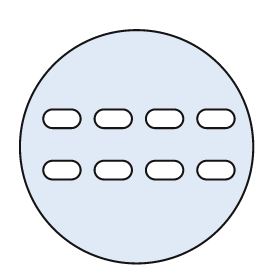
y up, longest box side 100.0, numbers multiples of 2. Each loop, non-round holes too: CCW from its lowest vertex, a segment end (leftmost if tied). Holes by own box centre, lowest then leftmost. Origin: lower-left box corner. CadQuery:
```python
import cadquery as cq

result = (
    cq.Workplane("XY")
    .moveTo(50.0, 50.0)
    .circle(50.0)
    .moveTo(14.0, 36.0)
    .lineTo(22.0, 36.0)
    .threePointArc((26.0, 40.0), (22.0, 44.0))
    .lineTo(14.0, 44.0)
    .threePointArc((10.0, 40.0), (14.0, 36.0))
    .close()
    .moveTo(36.0, 36.0)
    .lineTo(44.0, 36.0)
    .threePointArc((48.0, 40.0), (44.0, 44.0))
    .lineTo(36.0, 44.0)
    .threePointArc((32.0, 40.0), (36.0, 36.0))
    .close()
    .moveTo(58.0, 36.0)
    .lineTo(66.0, 36.0)
    .threePointArc((70.0, 40.0), (66.0, 44.0))
    .lineTo(58.0, 44.0)
    .threePointArc((54.0, 40.0), (58.0, 36.0))
    .close()
    .moveTo(80.0, 36.0)
    .lineTo(88.0, 36.0)
    .threePointArc((92.0, 40.0), (88.0, 44.0))
    .lineTo(80.0, 44.0)
    .threePointArc((76.0, 40.0), (80.0, 36.0))
    .close()
    .moveTo(14.0, 58.0)
    .lineTo(22.0, 58.0)
    .threePointArc((26.0, 62.0), (22.0, 66.0))
    .lineTo(14.0, 66.0)
    .threePointArc((10.0, 62.0), (14.0, 58.0))
    .close()
    .moveTo(36.0, 58.0)
    .lineTo(44.0, 58.0)
    .threePointArc((48.0, 62.0), (44.0, 66.0))
    .lineTo(36.0, 66.0)
    .threePointArc((32.0, 62.0), (36.0, 58.0))
    .close()
    .moveTo(58.0, 58.0)
    .lineTo(66.0, 58.0)
    .threePointArc((70.0, 62.0), (66.0, 66.0))
    .lineTo(58.0, 66.0)
    .threePointArc((54.0, 62.0), (58.0, 58.0))
    .close()
    .moveTo(80.0, 58.0)
    .lineTo(88.0, 58.0)
    .threePointArc((92.0, 62.0), (88.0, 66.0))
    .lineTo(80.0, 66.0)
    .threePointArc((76.0, 62.0), (80.0, 58.0))
    .close()
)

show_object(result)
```